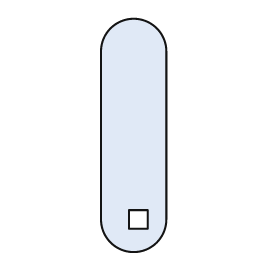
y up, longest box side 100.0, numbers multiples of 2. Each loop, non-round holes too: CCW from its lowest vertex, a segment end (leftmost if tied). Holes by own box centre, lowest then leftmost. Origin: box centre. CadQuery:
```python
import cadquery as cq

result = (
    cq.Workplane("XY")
    .moveTo(-14.0, -36.0)
    .threePointArc((0.0, -50.0), (14.0, -36.0))
    .lineTo(14.0, 36.0)
    .threePointArc((0.0, 50.0), (-14.0, 36.0))
    .close()
    .moveTo(-2.0, -40.0)
    .lineTo(6.0, -40.0)
    .lineTo(6.0, -32.0)
    .lineTo(-2.0, -32.0)
    .close()
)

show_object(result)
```